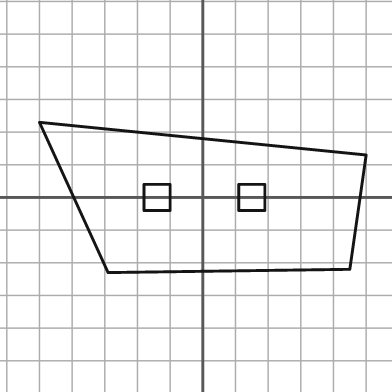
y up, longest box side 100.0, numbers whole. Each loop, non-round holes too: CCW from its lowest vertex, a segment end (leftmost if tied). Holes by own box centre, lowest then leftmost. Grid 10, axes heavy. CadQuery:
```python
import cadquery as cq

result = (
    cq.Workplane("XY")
    .moveTo(-29.0, -23.0)
    .lineTo(45.0, -22.0)
    .lineTo(50.0, 13.0)
    .lineTo(-50.0, 23.0)
    .close()
    .moveTo(-18.0, -4.0)
    .lineTo(-10.0, -4.0)
    .lineTo(-10.0, 4.0)
    .lineTo(-18.0, 4.0)
    .close()
    .moveTo(11.0, -4.0)
    .lineTo(19.0, -4.0)
    .lineTo(19.0, 4.0)
    .lineTo(11.0, 4.0)
    .close()
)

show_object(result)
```